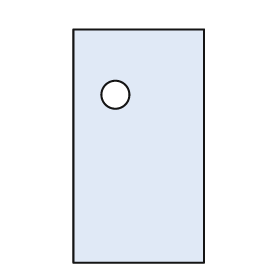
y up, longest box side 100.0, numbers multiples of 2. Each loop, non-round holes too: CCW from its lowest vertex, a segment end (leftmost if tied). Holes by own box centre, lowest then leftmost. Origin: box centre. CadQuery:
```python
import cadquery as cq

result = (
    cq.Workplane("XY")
    .moveTo(-28.0, -50.0)
    .lineTo(28.0, -50.0)
    .lineTo(28.0, 50.0)
    .lineTo(-28.0, 50.0)
    .close()
    .moveTo(-10.0, 22.0)
    .circle(6.0)
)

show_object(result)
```